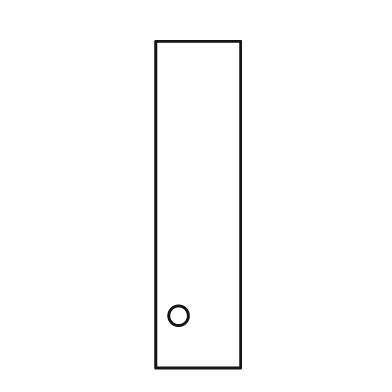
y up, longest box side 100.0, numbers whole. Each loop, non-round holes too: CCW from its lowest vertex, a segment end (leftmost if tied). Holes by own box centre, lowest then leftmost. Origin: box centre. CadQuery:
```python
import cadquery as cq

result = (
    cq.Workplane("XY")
    .moveTo(-13.0, -50.0)
    .lineTo(13.0, -50.0)
    .lineTo(13.0, 50.0)
    .lineTo(-13.0, 50.0)
    .close()
    .moveTo(-6.0, -34.0)
    .circle(3.0)
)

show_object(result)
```